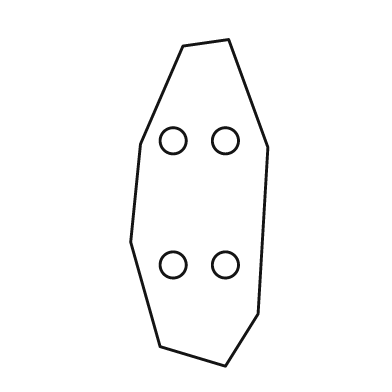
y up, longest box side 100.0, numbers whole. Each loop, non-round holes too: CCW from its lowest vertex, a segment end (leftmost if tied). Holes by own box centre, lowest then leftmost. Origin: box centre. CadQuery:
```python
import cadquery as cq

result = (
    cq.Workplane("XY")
    .moveTo(8.0, -50.0)
    .lineTo(18.0, -34.0)
    .lineTo(21.0, 17.0)
    .lineTo(9.0, 50.0)
    .lineTo(-5.0, 48.0)
    .lineTo(-18.0, 18.0)
    .lineTo(-21.0, -12.0)
    .lineTo(-12.0, -44.0)
    .close()
    .moveTo(-8.0, -19.0)
    .circle(4.0)
    .moveTo(8.0, -19.0)
    .circle(4.0)
    .moveTo(-8.0, 19.0)
    .circle(4.0)
    .moveTo(8.0, 19.0)
    .circle(4.0)
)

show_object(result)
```